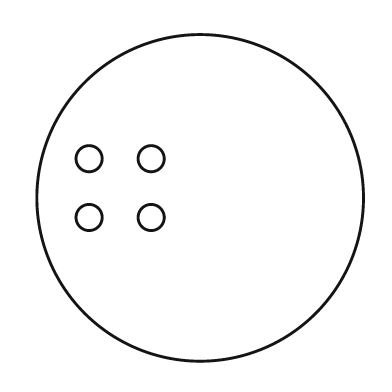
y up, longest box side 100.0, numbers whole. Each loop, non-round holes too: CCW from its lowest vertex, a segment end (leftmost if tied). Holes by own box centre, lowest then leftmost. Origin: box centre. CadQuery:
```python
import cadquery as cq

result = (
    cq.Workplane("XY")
    .moveTo(0.0, 0.0)
    .circle(50.0)
    .moveTo(-34.0, -6.0)
    .circle(4.0)
    .moveTo(-15.0, -6.0)
    .circle(4.0)
    .moveTo(-34.0, 12.0)
    .circle(4.0)
    .moveTo(-15.0, 12.0)
    .circle(4.0)
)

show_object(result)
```